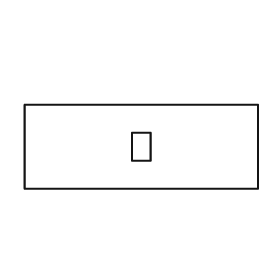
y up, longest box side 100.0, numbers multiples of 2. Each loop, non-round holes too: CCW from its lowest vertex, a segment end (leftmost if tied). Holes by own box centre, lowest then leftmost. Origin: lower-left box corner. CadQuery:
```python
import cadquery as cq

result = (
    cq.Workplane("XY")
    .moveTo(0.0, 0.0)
    .lineTo(100.0, 0.0)
    .lineTo(100.0, 36.0)
    .lineTo(0.0, 36.0)
    .close()
    .moveTo(46.0, 12.0)
    .lineTo(54.0, 12.0)
    .lineTo(54.0, 24.0)
    .lineTo(46.0, 24.0)
    .close()
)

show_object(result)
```